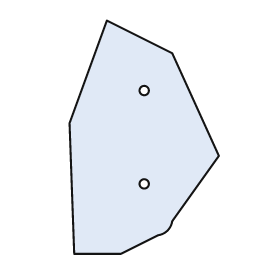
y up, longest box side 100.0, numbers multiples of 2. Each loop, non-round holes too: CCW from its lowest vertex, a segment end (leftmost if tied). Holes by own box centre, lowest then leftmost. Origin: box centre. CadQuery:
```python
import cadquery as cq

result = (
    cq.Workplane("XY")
    .moveTo(-30.0, -50.0)
    .lineTo(-10.0, -50.0)
    .lineTo(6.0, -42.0)
    .threePointArc((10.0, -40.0), (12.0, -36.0))
    .lineTo(32.0, -8.0)
    .lineTo(12.0, 36.0)
    .lineTo(-16.0, 50.0)
    .lineTo(-32.0, 6.0)
    .close()
    .moveTo(0.0, -20.0)
    .circle(2.0)
    .moveTo(0.0, 20.0)
    .circle(2.0)
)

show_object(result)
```